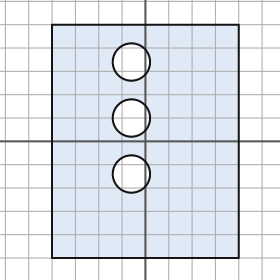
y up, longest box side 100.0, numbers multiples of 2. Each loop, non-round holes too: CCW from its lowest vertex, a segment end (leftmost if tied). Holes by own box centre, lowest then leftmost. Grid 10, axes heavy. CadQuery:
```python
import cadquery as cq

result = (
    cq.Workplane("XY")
    .moveTo(-40.0, -50.0)
    .lineTo(40.0, -50.0)
    .lineTo(40.0, 50.0)
    .lineTo(-40.0, 50.0)
    .close()
    .moveTo(-6.0, -14.0)
    .circle(8.0)
    .moveTo(-6.0, 10.0)
    .circle(8.0)
    .moveTo(-6.0, 34.0)
    .circle(8.0)
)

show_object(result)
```